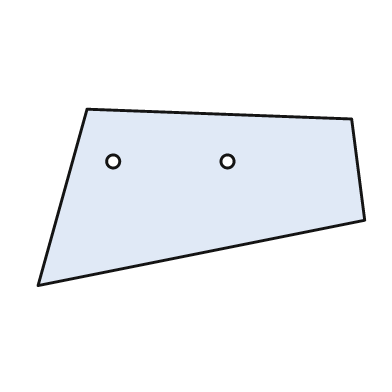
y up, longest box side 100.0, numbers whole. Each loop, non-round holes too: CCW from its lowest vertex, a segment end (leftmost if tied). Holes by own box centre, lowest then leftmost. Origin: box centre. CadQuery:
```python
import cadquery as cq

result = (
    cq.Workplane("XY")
    .moveTo(-50.0, -27.0)
    .lineTo(50.0, -7.0)
    .lineTo(46.0, 24.0)
    .lineTo(-35.0, 27.0)
    .close()
    .moveTo(-27.0, 11.0)
    .circle(2.0)
    .moveTo(8.0, 11.0)
    .circle(2.0)
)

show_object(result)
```